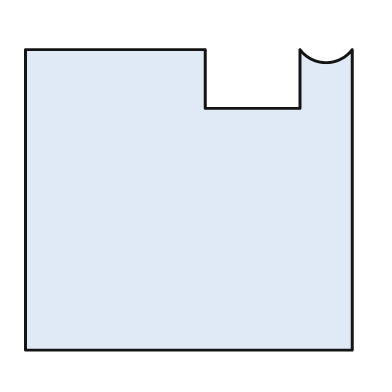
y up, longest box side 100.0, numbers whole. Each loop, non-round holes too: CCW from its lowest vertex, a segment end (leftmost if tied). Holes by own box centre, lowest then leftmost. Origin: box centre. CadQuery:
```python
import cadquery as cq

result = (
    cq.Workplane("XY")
    .moveTo(-50.0, -46.0)
    .lineTo(50.0, -46.0)
    .lineTo(50.0, 46.0)
    .threePointArc((42.0, 42.0), (34.0, 46.0))
    .lineTo(34.0, 28.0)
    .lineTo(5.0, 28.0)
    .lineTo(5.0, 46.0)
    .lineTo(-50.0, 46.0)
    .close()
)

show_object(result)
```